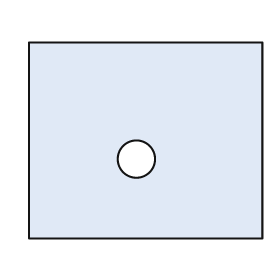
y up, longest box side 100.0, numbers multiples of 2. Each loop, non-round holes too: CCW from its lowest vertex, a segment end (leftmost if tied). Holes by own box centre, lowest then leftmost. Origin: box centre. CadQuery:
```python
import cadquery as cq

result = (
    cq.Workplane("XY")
    .moveTo(-50.0, -42.0)
    .lineTo(50.0, -42.0)
    .lineTo(50.0, 42.0)
    .lineTo(-50.0, 42.0)
    .close()
    .moveTo(-4.0, -8.0)
    .circle(8.0)
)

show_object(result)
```